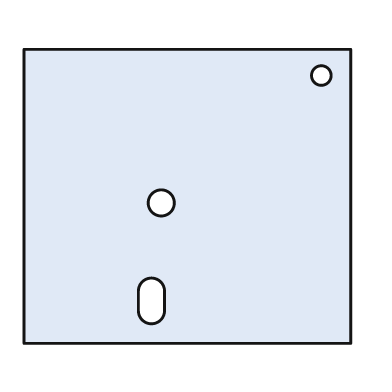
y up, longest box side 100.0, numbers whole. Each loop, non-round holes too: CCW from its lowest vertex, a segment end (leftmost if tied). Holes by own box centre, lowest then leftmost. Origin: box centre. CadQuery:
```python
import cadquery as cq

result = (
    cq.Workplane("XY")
    .moveTo(-50.0, -45.0)
    .lineTo(50.0, -45.0)
    .lineTo(50.0, 45.0)
    .lineTo(-50.0, 45.0)
    .close()
    .moveTo(-15.0, -35.0)
    .threePointArc((-11.0, -39.0), (-7.0, -35.0))
    .lineTo(-7.0, -29.0)
    .threePointArc((-11.0, -25.0), (-15.0, -29.0))
    .close()
    .moveTo(-8.0, -2.0)
    .circle(4.0)
    .moveTo(41.0, 37.0)
    .circle(3.0)
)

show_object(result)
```